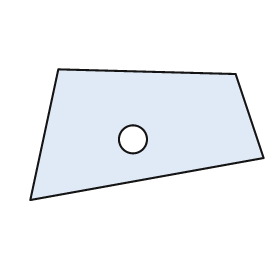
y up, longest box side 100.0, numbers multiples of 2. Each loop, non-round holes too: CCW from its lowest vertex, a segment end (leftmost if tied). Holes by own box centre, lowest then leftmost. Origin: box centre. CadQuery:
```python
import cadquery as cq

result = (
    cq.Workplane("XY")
    .moveTo(-50.0, -28.0)
    .lineTo(50.0, -10.0)
    .lineTo(38.0, 26.0)
    .lineTo(-38.0, 28.0)
    .close()
    .moveTo(-6.0, -2.0)
    .circle(6.0)
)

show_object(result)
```